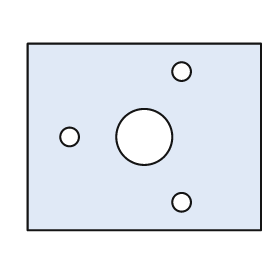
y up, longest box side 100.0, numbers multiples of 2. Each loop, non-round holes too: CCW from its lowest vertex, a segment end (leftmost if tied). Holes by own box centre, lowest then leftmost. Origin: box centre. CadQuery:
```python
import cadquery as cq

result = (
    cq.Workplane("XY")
    .moveTo(-50.0, -40.0)
    .lineTo(50.0, -40.0)
    .lineTo(50.0, 40.0)
    .lineTo(-50.0, 40.0)
    .close()
    .moveTo(16.0, -28.0)
    .circle(4.0)
    .moveTo(-32.0, 0.0)
    .circle(4.0)
    .moveTo(0.0, 0.0)
    .circle(12.0)
    .moveTo(16.0, 28.0)
    .circle(4.0)
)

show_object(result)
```